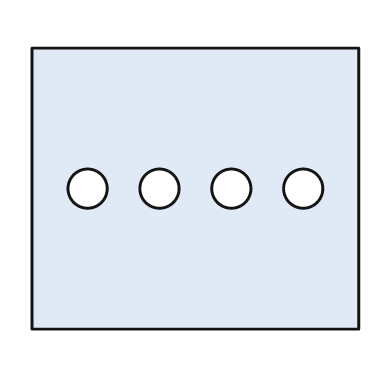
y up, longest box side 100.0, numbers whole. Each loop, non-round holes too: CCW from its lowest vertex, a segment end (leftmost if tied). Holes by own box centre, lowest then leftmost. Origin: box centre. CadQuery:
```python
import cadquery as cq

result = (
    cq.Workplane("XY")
    .moveTo(-50.0, -43.0)
    .lineTo(50.0, -43.0)
    .lineTo(50.0, 43.0)
    .lineTo(-50.0, 43.0)
    .close()
    .moveTo(-33.0, 0.0)
    .circle(6.0)
    .moveTo(-11.0, 0.0)
    .circle(6.0)
    .moveTo(11.0, 0.0)
    .circle(6.0)
    .moveTo(33.0, 0.0)
    .circle(6.0)
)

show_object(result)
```